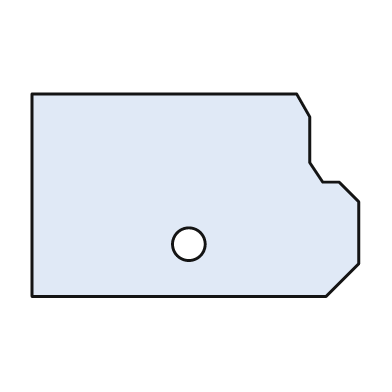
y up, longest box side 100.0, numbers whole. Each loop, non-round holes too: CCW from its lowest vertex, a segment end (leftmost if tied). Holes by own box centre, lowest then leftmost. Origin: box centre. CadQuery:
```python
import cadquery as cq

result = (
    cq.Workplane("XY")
    .moveTo(-50.0, -31.0)
    .lineTo(40.0, -31.0)
    .lineTo(50.0, -21.0)
    .lineTo(50.0, -2.0)
    .lineTo(44.0, 4.0)
    .lineTo(39.0, 4.0)
    .lineTo(35.0, 10.0)
    .lineTo(35.0, 24.0)
    .lineTo(31.0, 31.0)
    .lineTo(-50.0, 31.0)
    .close()
    .moveTo(-2.0, -15.0)
    .circle(5.0)
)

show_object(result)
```